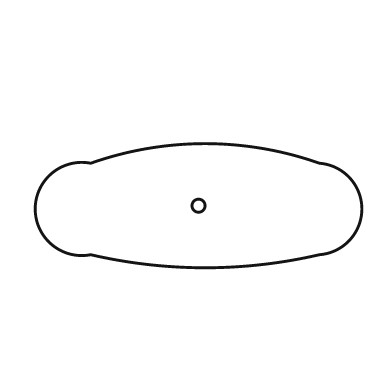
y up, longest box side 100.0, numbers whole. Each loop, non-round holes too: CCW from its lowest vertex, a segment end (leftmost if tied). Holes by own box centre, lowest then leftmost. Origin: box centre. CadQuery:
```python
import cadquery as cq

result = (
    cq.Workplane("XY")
    .moveTo(-33.0, -15.0)
    .threePointArc((2.0, -19.0), (37.0, -15.0))
    .threePointArc((50.0, -1.0), (37.0, 13.0))
    .threePointArc((2.0, 19.0), (-33.0, 13.0))
    .threePointArc((-50.0, -1.0), (-33.0, -15.0))
    .close()
    .moveTo(0.0, 0.0)
    .circle(2.0)
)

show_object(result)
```